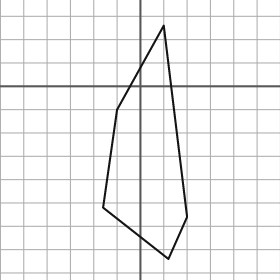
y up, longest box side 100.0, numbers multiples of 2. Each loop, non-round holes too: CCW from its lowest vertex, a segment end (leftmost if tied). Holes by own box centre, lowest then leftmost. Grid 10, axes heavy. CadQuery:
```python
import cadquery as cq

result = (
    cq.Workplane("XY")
    .moveTo(12.0, -74.0)
    .lineTo(20.0, -56.0)
    .lineTo(10.0, 26.0)
    .lineTo(-10.0, -10.0)
    .lineTo(-16.0, -52.0)
    .close()
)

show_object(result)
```